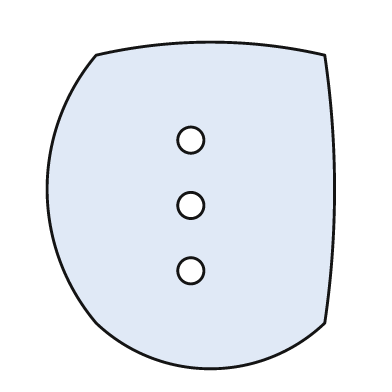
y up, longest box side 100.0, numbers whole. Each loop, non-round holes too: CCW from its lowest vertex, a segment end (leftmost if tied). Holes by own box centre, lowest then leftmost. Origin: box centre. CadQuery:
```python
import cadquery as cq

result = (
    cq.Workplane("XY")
    .moveTo(-29.0, -36.0)
    .threePointArc((6.0, -50.0), (41.0, -36.0))
    .threePointArc((44.0, 5.0), (41.0, 46.0))
    .threePointArc((6.0, 50.0), (-29.0, 46.0))
    .threePointArc((-44.0, 5.0), (-29.0, -36.0))
    .close()
    .moveTo(0.0, -20.0)
    .circle(4.0)
    .moveTo(0.0, 0.0)
    .circle(4.0)
    .moveTo(0.0, 20.0)
    .circle(4.0)
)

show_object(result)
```